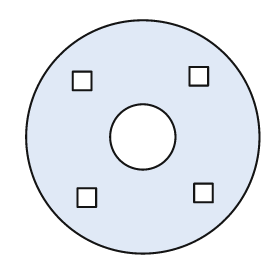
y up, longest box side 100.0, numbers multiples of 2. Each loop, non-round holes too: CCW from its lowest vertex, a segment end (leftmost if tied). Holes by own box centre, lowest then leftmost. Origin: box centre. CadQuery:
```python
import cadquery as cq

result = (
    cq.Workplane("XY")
    .moveTo(0.0, 0.0)
    .circle(50.0)
    .moveTo(-28.0, -30.0)
    .lineTo(-20.0, -30.0)
    .lineTo(-20.0, -22.0)
    .lineTo(-28.0, -22.0)
    .close()
    .moveTo(22.0, -28.0)
    .lineTo(30.0, -28.0)
    .lineTo(30.0, -20.0)
    .lineTo(22.0, -20.0)
    .close()
    .moveTo(0.0, 0.0)
    .circle(14.0)
    .moveTo(-30.0, 20.0)
    .lineTo(-22.0, 20.0)
    .lineTo(-22.0, 28.0)
    .lineTo(-30.0, 28.0)
    .close()
    .moveTo(20.0, 22.0)
    .lineTo(28.0, 22.0)
    .lineTo(28.0, 30.0)
    .lineTo(20.0, 30.0)
    .close()
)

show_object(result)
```